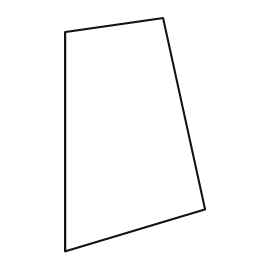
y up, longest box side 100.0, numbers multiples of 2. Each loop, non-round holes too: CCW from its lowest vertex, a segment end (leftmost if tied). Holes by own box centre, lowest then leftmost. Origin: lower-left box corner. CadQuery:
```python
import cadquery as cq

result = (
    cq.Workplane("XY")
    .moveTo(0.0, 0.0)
    .lineTo(60.0, 18.0)
    .lineTo(42.0, 100.0)
    .lineTo(0.0, 94.0)
    .close()
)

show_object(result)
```